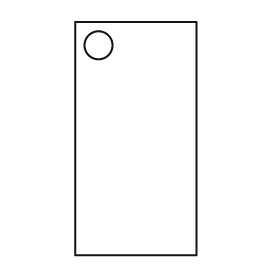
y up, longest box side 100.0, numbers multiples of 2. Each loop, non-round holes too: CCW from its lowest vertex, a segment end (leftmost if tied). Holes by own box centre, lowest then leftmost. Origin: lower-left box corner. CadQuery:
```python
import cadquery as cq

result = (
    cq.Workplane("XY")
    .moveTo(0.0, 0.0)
    .lineTo(52.0, 0.0)
    .lineTo(52.0, 100.0)
    .lineTo(0.0, 100.0)
    .close()
    .moveTo(10.0, 90.0)
    .circle(6.0)
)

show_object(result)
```